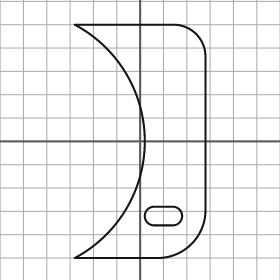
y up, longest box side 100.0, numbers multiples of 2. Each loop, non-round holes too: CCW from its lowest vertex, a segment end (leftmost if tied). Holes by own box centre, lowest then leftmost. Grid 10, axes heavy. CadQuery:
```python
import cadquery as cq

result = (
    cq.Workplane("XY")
    .moveTo(-28.0, -50.0)
    .lineTo(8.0, -50.0)
    .threePointArc((22.0, -44.0), (28.0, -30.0))
    .lineTo(28.0, 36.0)
    .threePointArc((24.0, 46.0), (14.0, 50.0))
    .lineTo(-28.0, 50.0)
    .threePointArc((2.0, 0.0), (-28.0, -50.0))
    .close()
    .moveTo(6.0, -36.0)
    .lineTo(14.0, -36.0)
    .threePointArc((18.0, -32.0), (14.0, -28.0))
    .lineTo(6.0, -28.0)
    .threePointArc((2.0, -32.0), (6.0, -36.0))
    .close()
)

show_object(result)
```